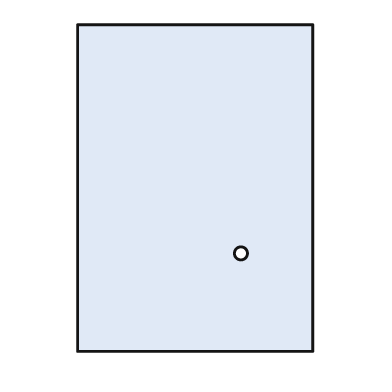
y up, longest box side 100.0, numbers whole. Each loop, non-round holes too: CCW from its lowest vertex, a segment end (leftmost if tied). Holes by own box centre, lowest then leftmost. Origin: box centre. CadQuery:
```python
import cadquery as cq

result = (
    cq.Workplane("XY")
    .moveTo(-36.0, -50.0)
    .lineTo(36.0, -50.0)
    .lineTo(36.0, 50.0)
    .lineTo(-36.0, 50.0)
    .close()
    .moveTo(14.0, -20.0)
    .circle(2.0)
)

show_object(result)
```